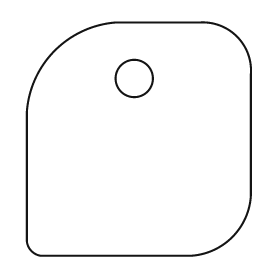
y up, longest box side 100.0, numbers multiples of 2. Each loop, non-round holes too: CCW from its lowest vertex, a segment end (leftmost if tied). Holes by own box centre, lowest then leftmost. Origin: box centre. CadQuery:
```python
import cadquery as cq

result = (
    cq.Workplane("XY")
    .moveTo(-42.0, -50.0)
    .lineTo(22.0, -50.0)
    .threePointArc((40.0, -42.0), (48.0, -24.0))
    .lineTo(48.0, 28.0)
    .threePointArc((42.0, 44.0), (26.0, 50.0))
    .lineTo(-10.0, 50.0)
    .threePointArc((-36.0, 38.0), (-48.0, 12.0))
    .lineTo(-48.0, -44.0)
    .threePointArc((-46.0, -48.0), (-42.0, -50.0))
    .close()
    .moveTo(-2.0, 26.0)
    .circle(8.0)
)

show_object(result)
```